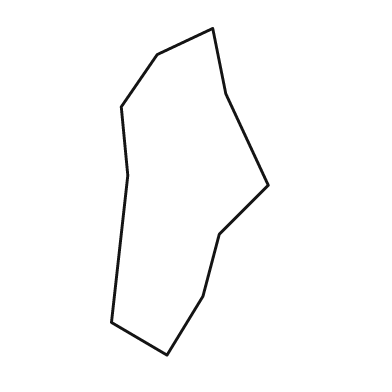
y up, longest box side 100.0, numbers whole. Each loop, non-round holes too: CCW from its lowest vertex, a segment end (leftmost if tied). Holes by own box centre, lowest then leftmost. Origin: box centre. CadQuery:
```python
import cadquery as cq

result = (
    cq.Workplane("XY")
    .moveTo(-7.0, -50.0)
    .lineTo(4.0, -32.0)
    .lineTo(9.0, -13.0)
    .lineTo(24.0, 2.0)
    .lineTo(11.0, 30.0)
    .lineTo(7.0, 50.0)
    .lineTo(-10.0, 42.0)
    .lineTo(-21.0, 26.0)
    .lineTo(-19.0, 5.0)
    .lineTo(-24.0, -40.0)
    .close()
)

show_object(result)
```